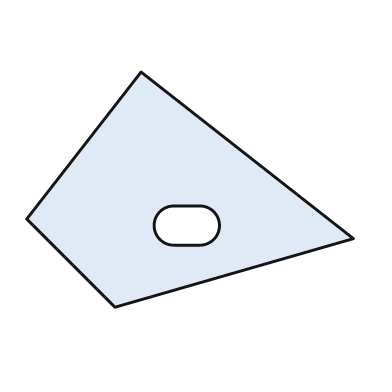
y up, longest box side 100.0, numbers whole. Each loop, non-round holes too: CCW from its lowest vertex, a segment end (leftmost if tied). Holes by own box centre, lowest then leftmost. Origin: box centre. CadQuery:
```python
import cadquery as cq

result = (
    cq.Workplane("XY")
    .moveTo(-23.0, -36.0)
    .lineTo(50.0, -15.0)
    .lineTo(-15.0, 36.0)
    .lineTo(-50.0, -9.0)
    .close()
    .moveTo(-5.0, -17.0)
    .lineTo(3.0, -17.0)
    .threePointArc((9.0, -11.0), (3.0, -5.0))
    .lineTo(-5.0, -5.0)
    .threePointArc((-11.0, -11.0), (-5.0, -17.0))
    .close()
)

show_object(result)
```